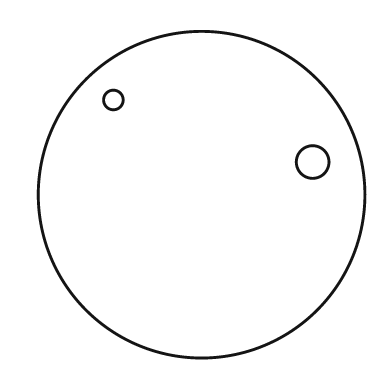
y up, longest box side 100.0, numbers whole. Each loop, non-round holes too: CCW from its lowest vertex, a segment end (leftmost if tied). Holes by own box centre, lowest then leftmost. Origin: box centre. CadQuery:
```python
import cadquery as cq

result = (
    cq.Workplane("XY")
    .moveTo(0.0, 0.0)
    .circle(50.0)
    .moveTo(34.0, 10.0)
    .circle(5.0)
    .moveTo(-27.0, 29.0)
    .circle(3.0)
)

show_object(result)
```